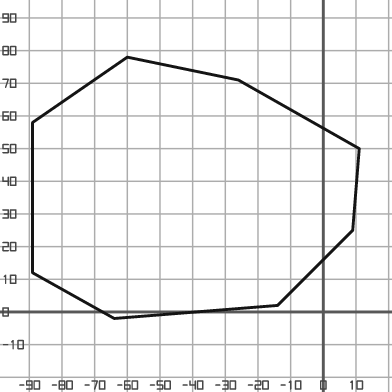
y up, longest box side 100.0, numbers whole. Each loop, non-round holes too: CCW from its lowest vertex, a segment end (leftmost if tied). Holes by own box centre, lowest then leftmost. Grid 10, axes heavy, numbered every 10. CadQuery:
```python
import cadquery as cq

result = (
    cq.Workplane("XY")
    .moveTo(-64.0, -2.0)
    .lineTo(-14.0, 2.0)
    .lineTo(9.0, 25.0)
    .lineTo(11.0, 50.0)
    .lineTo(-26.0, 71.0)
    .lineTo(-60.0, 78.0)
    .lineTo(-89.0, 58.0)
    .lineTo(-89.0, 12.0)
    .close()
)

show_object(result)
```